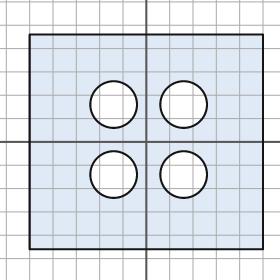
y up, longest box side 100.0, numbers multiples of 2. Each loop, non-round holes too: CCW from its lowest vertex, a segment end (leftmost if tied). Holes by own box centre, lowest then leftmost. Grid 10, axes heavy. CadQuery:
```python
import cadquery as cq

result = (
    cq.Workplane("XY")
    .moveTo(-50.0, -46.0)
    .lineTo(50.0, -46.0)
    .lineTo(50.0, 46.0)
    .lineTo(-50.0, 46.0)
    .close()
    .moveTo(-14.0, -14.0)
    .circle(10.0)
    .moveTo(16.0, -14.0)
    .circle(10.0)
    .moveTo(-14.0, 16.0)
    .circle(10.0)
    .moveTo(16.0, 16.0)
    .circle(10.0)
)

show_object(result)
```